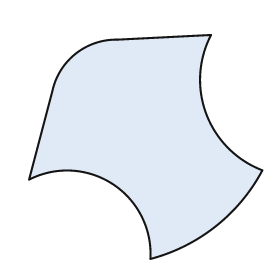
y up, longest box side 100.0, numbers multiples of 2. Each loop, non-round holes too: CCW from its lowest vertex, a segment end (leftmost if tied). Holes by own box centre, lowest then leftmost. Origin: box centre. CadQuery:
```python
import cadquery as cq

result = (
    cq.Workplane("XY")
    .moveTo(2.0, -48.0)
    .threePointArc((30.0, -34.0), (50.0, -10.0))
    .threePointArc((26.0, 14.0), (28.0, 48.0))
    .lineTo(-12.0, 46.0)
    .threePointArc((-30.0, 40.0), (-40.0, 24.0))
    .lineTo(-50.0, -14.0)
    .threePointArc((-14.0, -16.0), (2.0, -48.0))
    .close()
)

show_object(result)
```